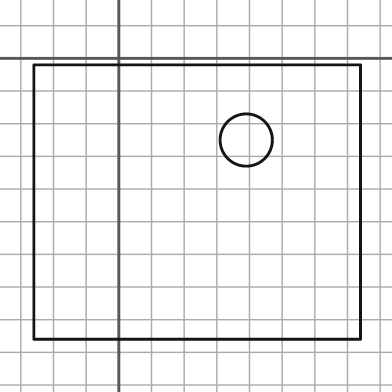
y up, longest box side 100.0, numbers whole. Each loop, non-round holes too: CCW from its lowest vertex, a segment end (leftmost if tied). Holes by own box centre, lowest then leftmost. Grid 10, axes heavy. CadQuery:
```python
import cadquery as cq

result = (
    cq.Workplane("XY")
    .moveTo(-26.0, -86.0)
    .lineTo(74.0, -86.0)
    .lineTo(74.0, -2.0)
    .lineTo(-26.0, -2.0)
    .close()
    .moveTo(39.0, -25.0)
    .circle(8.0)
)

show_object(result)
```